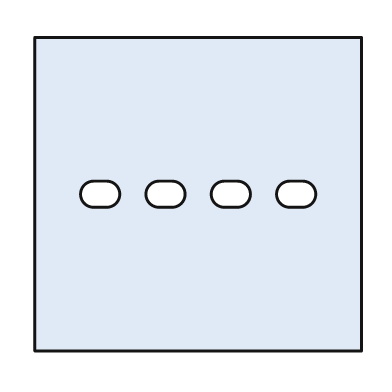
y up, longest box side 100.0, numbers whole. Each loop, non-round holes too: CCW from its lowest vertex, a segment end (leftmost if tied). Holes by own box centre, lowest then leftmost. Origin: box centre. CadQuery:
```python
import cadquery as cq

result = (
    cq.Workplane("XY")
    .moveTo(-50.0, -48.0)
    .lineTo(50.0, -48.0)
    .lineTo(50.0, 48.0)
    .lineTo(-50.0, 48.0)
    .close()
    .moveTo(-32.0, -4.0)
    .lineTo(-28.0, -4.0)
    .threePointArc((-24.0, 0.0), (-28.0, 4.0))
    .lineTo(-32.0, 4.0)
    .threePointArc((-36.0, 0.0), (-32.0, -4.0))
    .close()
    .moveTo(-12.0, -4.0)
    .lineTo(-8.0, -4.0)
    .threePointArc((-4.0, 0.0), (-8.0, 4.0))
    .lineTo(-12.0, 4.0)
    .threePointArc((-16.0, 0.0), (-12.0, -4.0))
    .close()
    .moveTo(8.0, -4.0)
    .lineTo(12.0, -4.0)
    .threePointArc((16.0, 0.0), (12.0, 4.0))
    .lineTo(8.0, 4.0)
    .threePointArc((4.0, 0.0), (8.0, -4.0))
    .close()
    .moveTo(28.0, -4.0)
    .lineTo(32.0, -4.0)
    .threePointArc((36.0, 0.0), (32.0, 4.0))
    .lineTo(28.0, 4.0)
    .threePointArc((24.0, 0.0), (28.0, -4.0))
    .close()
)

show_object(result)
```